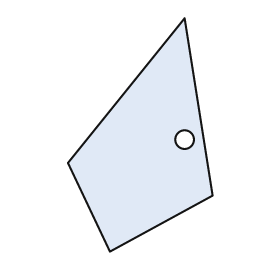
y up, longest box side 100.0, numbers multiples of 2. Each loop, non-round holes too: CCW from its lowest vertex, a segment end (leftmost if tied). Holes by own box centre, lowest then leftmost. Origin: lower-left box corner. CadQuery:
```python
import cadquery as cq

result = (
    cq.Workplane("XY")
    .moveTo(18.0, 0.0)
    .lineTo(62.0, 24.0)
    .lineTo(50.0, 100.0)
    .lineTo(0.0, 38.0)
    .close()
    .moveTo(50.0, 48.0)
    .circle(4.0)
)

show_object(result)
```